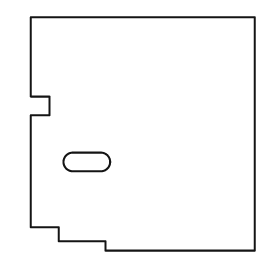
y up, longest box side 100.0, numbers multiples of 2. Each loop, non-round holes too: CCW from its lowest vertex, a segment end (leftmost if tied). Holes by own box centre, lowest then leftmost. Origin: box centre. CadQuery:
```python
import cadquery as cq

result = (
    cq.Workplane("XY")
    .moveTo(-16.0, -50.0)
    .lineTo(48.0, -50.0)
    .lineTo(48.0, 50.0)
    .lineTo(-48.0, 50.0)
    .lineTo(-48.0, 16.0)
    .lineTo(-40.0, 16.0)
    .lineTo(-40.0, 8.0)
    .lineTo(-48.0, 8.0)
    .lineTo(-48.0, -40.0)
    .lineTo(-36.0, -40.0)
    .lineTo(-36.0, -46.0)
    .lineTo(-16.0, -46.0)
    .close()
    .moveTo(-30.0, -16.0)
    .lineTo(-18.0, -16.0)
    .threePointArc((-14.0, -12.0), (-18.0, -8.0))
    .lineTo(-30.0, -8.0)
    .threePointArc((-34.0, -12.0), (-30.0, -16.0))
    .close()
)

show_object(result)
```